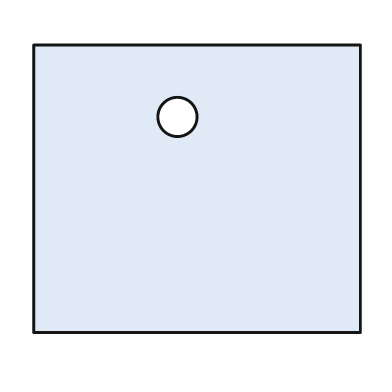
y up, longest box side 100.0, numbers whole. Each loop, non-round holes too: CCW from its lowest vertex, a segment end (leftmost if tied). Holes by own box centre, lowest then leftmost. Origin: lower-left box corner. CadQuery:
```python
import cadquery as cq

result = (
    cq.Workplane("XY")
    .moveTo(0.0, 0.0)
    .lineTo(100.0, 0.0)
    .lineTo(100.0, 88.0)
    .lineTo(0.0, 88.0)
    .close()
    .moveTo(44.0, 66.0)
    .circle(6.0)
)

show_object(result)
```